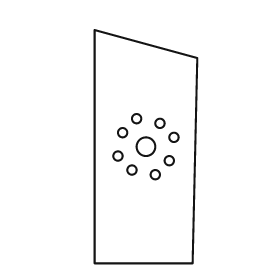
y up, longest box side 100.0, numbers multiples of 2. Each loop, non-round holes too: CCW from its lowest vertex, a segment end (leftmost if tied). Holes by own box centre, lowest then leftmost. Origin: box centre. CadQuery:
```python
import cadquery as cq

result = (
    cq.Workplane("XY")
    .moveTo(-22.0, -50.0)
    .lineTo(20.0, -50.0)
    .lineTo(22.0, 38.0)
    .lineTo(-22.0, 50.0)
    .close()
    .moveTo(4.0, -12.0)
    .circle(2.0)
    .moveTo(-6.0, -10.0)
    .circle(2.0)
    .moveTo(10.0, -6.0)
    .circle(2.0)
    .moveTo(-12.0, -4.0)
    .circle(2.0)
    .moveTo(0.0, 0.0)
    .circle(4.0)
    .moveTo(12.0, 4.0)
    .circle(2.0)
    .moveTo(-10.0, 6.0)
    .circle(2.0)
    .moveTo(6.0, 10.0)
    .circle(2.0)
    .moveTo(-4.0, 12.0)
    .circle(2.0)
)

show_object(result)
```